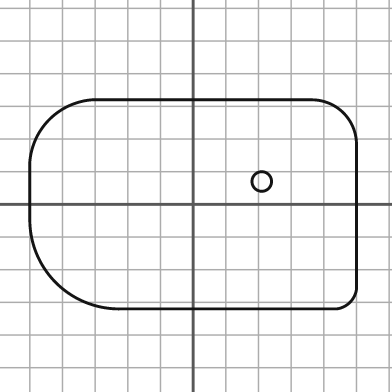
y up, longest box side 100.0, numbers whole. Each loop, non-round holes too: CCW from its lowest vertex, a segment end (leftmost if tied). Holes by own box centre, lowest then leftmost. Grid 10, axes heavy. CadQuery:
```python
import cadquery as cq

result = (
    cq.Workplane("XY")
    .moveTo(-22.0, -32.0)
    .lineTo(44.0, -32.0)
    .threePointArc((48.0, -30.0), (50.0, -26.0))
    .lineTo(50.0, 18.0)
    .threePointArc((46.0, 28.0), (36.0, 32.0))
    .lineTo(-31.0, 32.0)
    .threePointArc((-44.0, 26.0), (-50.0, 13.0))
    .lineTo(-50.0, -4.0)
    .threePointArc((-42.0, -24.0), (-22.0, -32.0))
    .close()
    .moveTo(21.0, 7.0)
    .circle(3.0)
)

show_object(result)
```